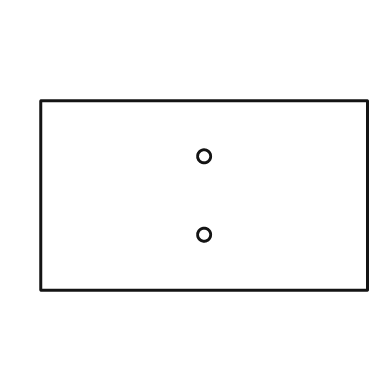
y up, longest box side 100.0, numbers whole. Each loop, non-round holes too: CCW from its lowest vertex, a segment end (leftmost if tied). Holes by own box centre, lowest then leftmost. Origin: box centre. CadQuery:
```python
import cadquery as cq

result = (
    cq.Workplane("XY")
    .moveTo(-50.0, -29.0)
    .lineTo(50.0, -29.0)
    .lineTo(50.0, 29.0)
    .lineTo(-50.0, 29.0)
    .close()
    .moveTo(0.0, -12.0)
    .circle(2.0)
    .moveTo(0.0, 12.0)
    .circle(2.0)
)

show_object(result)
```